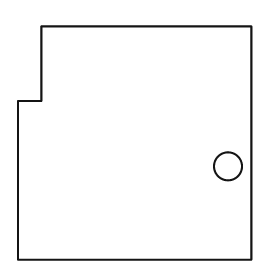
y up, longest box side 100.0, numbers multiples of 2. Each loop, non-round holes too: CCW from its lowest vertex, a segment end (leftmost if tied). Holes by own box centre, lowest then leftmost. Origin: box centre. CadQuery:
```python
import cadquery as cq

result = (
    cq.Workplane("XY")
    .moveTo(-50.0, -50.0)
    .lineTo(50.0, -50.0)
    .lineTo(50.0, 50.0)
    .lineTo(-40.0, 50.0)
    .lineTo(-40.0, 18.0)
    .lineTo(-50.0, 18.0)
    .close()
    .moveTo(40.0, -10.0)
    .circle(6.0)
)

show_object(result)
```